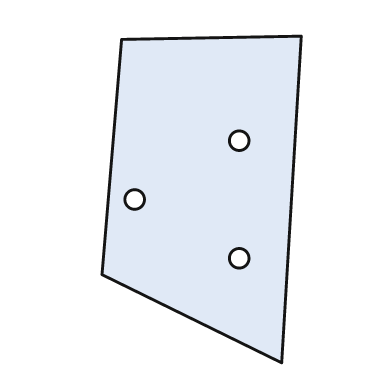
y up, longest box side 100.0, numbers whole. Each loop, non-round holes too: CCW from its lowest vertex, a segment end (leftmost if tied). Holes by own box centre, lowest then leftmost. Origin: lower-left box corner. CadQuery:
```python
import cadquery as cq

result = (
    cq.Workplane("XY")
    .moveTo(55.0, 0.0)
    .lineTo(61.0, 100.0)
    .lineTo(6.0, 99.0)
    .lineTo(0.0, 27.0)
    .close()
    .moveTo(42.0, 32.0)
    .circle(3.0)
    .moveTo(10.0, 50.0)
    .circle(3.0)
    .moveTo(42.0, 68.0)
    .circle(3.0)
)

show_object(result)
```